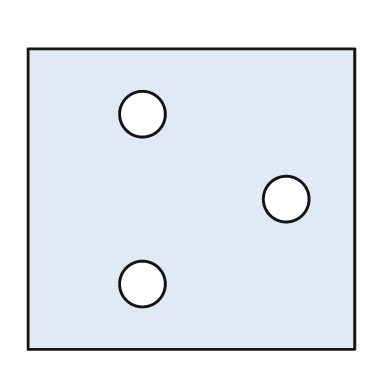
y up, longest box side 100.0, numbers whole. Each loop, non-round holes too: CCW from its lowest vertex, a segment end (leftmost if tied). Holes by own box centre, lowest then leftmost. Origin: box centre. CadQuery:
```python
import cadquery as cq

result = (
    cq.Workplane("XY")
    .moveTo(-50.0, -46.0)
    .lineTo(50.0, -46.0)
    .lineTo(50.0, 46.0)
    .lineTo(-50.0, 46.0)
    .close()
    .moveTo(-15.0, -26.0)
    .circle(7.0)
    .moveTo(29.0, 0.0)
    .circle(7.0)
    .moveTo(-15.0, 26.0)
    .circle(7.0)
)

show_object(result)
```